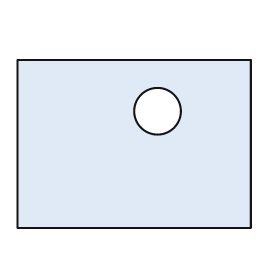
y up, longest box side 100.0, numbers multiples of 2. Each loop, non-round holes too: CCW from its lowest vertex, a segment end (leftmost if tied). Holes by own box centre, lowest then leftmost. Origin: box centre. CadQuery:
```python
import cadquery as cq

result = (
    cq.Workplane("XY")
    .moveTo(-50.0, -36.0)
    .lineTo(50.0, -36.0)
    .lineTo(50.0, 36.0)
    .lineTo(-50.0, 36.0)
    .close()
    .moveTo(10.0, 14.0)
    .circle(10.0)
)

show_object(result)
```